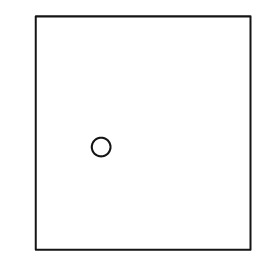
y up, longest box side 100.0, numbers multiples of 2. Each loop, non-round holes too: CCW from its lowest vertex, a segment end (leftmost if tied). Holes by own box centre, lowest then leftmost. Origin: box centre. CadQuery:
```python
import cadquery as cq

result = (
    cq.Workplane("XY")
    .moveTo(-46.0, -50.0)
    .lineTo(46.0, -50.0)
    .lineTo(46.0, 50.0)
    .lineTo(-46.0, 50.0)
    .close()
    .moveTo(-18.0, -6.0)
    .circle(4.0)
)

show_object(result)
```